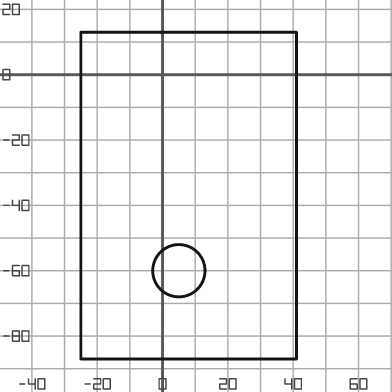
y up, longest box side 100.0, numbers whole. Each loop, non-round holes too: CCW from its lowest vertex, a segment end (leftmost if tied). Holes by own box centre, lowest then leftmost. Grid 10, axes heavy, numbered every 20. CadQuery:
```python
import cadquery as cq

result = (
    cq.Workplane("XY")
    .moveTo(-25.0, -87.0)
    .lineTo(41.0, -87.0)
    .lineTo(41.0, 13.0)
    .lineTo(-25.0, 13.0)
    .close()
    .moveTo(5.0, -60.0)
    .circle(8.0)
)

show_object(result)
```